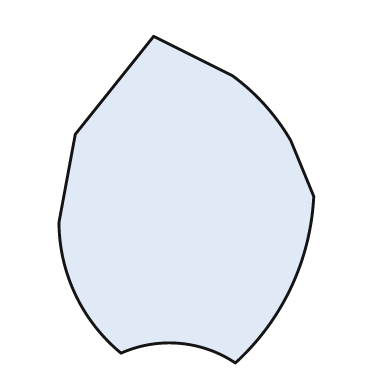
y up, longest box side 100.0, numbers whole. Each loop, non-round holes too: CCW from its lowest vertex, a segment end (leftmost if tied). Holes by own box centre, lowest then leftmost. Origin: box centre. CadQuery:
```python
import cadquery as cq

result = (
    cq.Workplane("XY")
    .moveTo(15.0, -50.0)
    .threePointArc((32.0, -27.0), (39.0, 1.0))
    .lineTo(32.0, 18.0)
    .threePointArc((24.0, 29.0), (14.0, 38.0))
    .lineTo(-10.0, 50.0)
    .lineTo(-34.0, 20.0)
    .lineTo(-39.0, -7.0)
    .threePointArc((-34.0, -29.0), (-20.0, -47.0))
    .threePointArc((-2.0, -44.0), (15.0, -50.0))
    .close()
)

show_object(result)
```